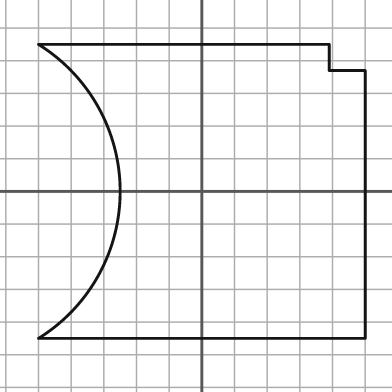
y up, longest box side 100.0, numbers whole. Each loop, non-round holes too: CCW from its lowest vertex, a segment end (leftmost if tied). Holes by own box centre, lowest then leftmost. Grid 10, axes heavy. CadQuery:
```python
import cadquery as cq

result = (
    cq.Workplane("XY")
    .moveTo(-50.0, -45.0)
    .lineTo(50.0, -45.0)
    .lineTo(50.0, 37.0)
    .lineTo(39.0, 37.0)
    .lineTo(39.0, 45.0)
    .lineTo(-50.0, 45.0)
    .threePointArc((-25.0, 0.0), (-50.0, -45.0))
    .close()
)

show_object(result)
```